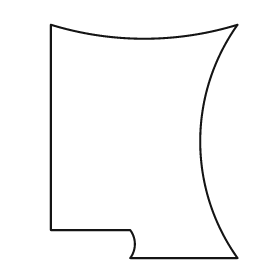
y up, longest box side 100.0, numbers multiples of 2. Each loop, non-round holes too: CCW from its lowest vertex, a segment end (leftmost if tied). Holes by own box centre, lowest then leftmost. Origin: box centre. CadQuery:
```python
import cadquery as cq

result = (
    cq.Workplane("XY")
    .moveTo(-6.0, -50.0)
    .lineTo(40.0, -50.0)
    .threePointArc((24.0, 0.0), (40.0, 50.0))
    .threePointArc((0.0, 44.0), (-40.0, 50.0))
    .lineTo(-40.0, -38.0)
    .lineTo(-6.0, -38.0)
    .threePointArc((-4.0, -44.0), (-6.0, -50.0))
    .close()
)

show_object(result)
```